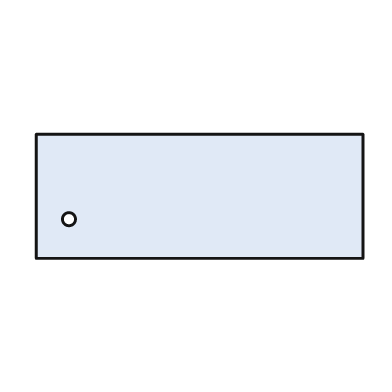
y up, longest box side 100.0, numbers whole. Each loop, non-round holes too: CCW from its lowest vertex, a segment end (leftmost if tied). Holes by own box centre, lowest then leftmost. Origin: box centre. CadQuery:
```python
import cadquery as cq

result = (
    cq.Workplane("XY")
    .moveTo(-50.0, -19.0)
    .lineTo(50.0, -19.0)
    .lineTo(50.0, 19.0)
    .lineTo(-50.0, 19.0)
    .close()
    .moveTo(-40.0, -7.0)
    .circle(2.0)
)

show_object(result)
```